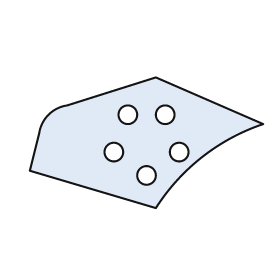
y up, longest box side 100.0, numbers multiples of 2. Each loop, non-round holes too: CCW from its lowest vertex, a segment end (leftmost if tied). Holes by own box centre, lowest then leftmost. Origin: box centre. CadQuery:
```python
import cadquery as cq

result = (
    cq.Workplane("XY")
    .moveTo(4.0, -28.0)
    .threePointArc((24.0, -6.0), (50.0, 8.0))
    .lineTo(4.0, 28.0)
    .lineTo(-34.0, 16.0)
    .threePointArc((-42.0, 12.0), (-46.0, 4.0))
    .lineTo(-50.0, -12.0)
    .close()
    .moveTo(0.0, -14.0)
    .circle(4.0)
    .moveTo(-14.0, -4.0)
    .circle(4.0)
    .moveTo(14.0, -4.0)
    .circle(4.0)
    .moveTo(-8.0, 12.0)
    .circle(4.0)
    .moveTo(8.0, 12.0)
    .circle(4.0)
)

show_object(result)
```